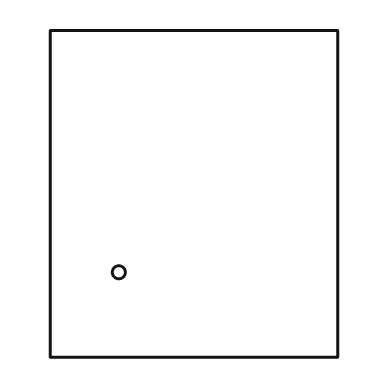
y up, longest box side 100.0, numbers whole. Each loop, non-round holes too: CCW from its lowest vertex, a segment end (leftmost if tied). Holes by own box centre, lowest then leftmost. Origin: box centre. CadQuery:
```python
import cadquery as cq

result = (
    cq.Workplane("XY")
    .moveTo(-44.0, -50.0)
    .lineTo(44.0, -50.0)
    .lineTo(44.0, 50.0)
    .lineTo(-44.0, 50.0)
    .close()
    .moveTo(-23.0, -24.0)
    .circle(2.0)
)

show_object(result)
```